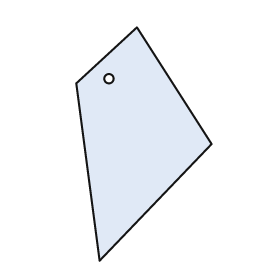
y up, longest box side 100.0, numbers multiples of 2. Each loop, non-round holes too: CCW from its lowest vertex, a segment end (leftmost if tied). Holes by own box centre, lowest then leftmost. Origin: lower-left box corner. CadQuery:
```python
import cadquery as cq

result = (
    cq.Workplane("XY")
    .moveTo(10.0, 0.0)
    .lineTo(58.0, 50.0)
    .lineTo(26.0, 100.0)
    .lineTo(0.0, 76.0)
    .close()
    .moveTo(14.0, 78.0)
    .circle(2.0)
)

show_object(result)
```